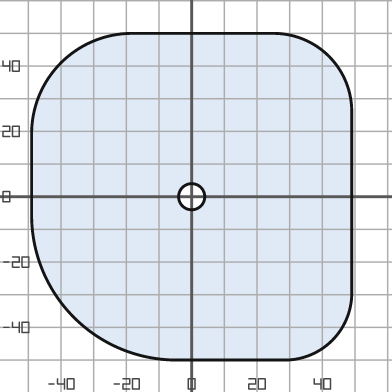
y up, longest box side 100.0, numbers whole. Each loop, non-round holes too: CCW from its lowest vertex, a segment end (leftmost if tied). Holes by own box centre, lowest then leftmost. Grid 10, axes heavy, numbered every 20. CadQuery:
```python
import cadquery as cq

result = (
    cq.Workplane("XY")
    .moveTo(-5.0, -50.0)
    .lineTo(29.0, -50.0)
    .threePointArc((43.0, -44.0), (49.0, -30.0))
    .lineTo(49.0, 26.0)
    .threePointArc((42.0, 43.0), (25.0, 50.0))
    .lineTo(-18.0, 50.0)
    .threePointArc((-40.0, 41.0), (-49.0, 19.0))
    .lineTo(-49.0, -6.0)
    .threePointArc((-36.0, -37.0), (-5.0, -50.0))
    .close()
    .moveTo(0.0, 0.0)
    .circle(4.0)
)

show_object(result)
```